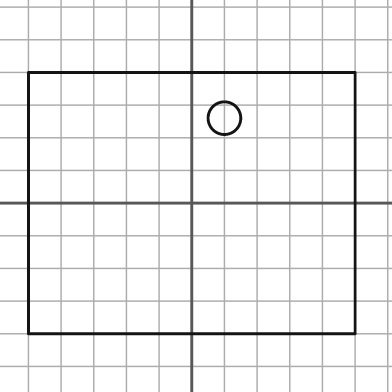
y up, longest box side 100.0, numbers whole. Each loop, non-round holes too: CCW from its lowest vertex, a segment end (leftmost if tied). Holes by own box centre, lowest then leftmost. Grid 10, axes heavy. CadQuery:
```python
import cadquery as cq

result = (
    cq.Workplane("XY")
    .moveTo(-50.0, -40.0)
    .lineTo(50.0, -40.0)
    .lineTo(50.0, 40.0)
    .lineTo(-50.0, 40.0)
    .close()
    .moveTo(10.0, 26.0)
    .circle(5.0)
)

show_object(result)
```